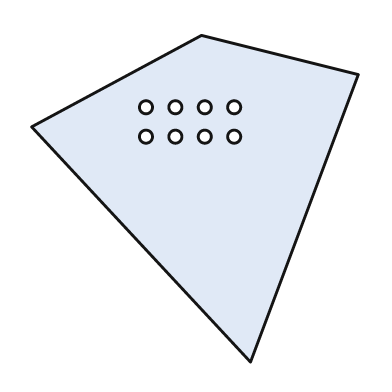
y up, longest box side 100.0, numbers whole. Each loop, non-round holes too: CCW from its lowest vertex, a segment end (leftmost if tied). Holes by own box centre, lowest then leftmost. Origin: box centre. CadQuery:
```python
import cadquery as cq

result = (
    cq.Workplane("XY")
    .moveTo(17.0, -50.0)
    .lineTo(50.0, 38.0)
    .lineTo(2.0, 50.0)
    .lineTo(-50.0, 22.0)
    .close()
    .moveTo(-15.0, 19.0)
    .circle(2.0)
    .moveTo(-6.0, 19.0)
    .circle(2.0)
    .moveTo(3.0, 19.0)
    .circle(2.0)
    .moveTo(12.0, 19.0)
    .circle(2.0)
    .moveTo(-15.0, 28.0)
    .circle(2.0)
    .moveTo(-6.0, 28.0)
    .circle(2.0)
    .moveTo(3.0, 28.0)
    .circle(2.0)
    .moveTo(12.0, 28.0)
    .circle(2.0)
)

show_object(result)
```